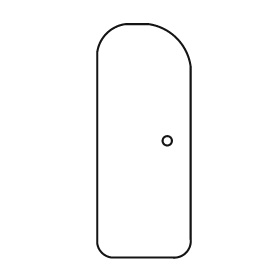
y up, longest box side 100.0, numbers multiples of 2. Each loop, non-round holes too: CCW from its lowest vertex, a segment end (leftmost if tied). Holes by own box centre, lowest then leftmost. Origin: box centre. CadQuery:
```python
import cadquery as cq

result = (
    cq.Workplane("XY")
    .moveTo(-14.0, -50.0)
    .lineTo(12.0, -50.0)
    .threePointArc((18.0, -48.0), (20.0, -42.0))
    .lineTo(20.0, 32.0)
    .threePointArc((14.0, 44.0), (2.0, 50.0))
    .lineTo(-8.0, 50.0)
    .threePointArc((-16.0, 46.0), (-20.0, 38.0))
    .lineTo(-20.0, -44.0)
    .threePointArc((-18.0, -48.0), (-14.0, -50.0))
    .close()
    .moveTo(10.0, 0.0)
    .circle(2.0)
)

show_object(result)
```